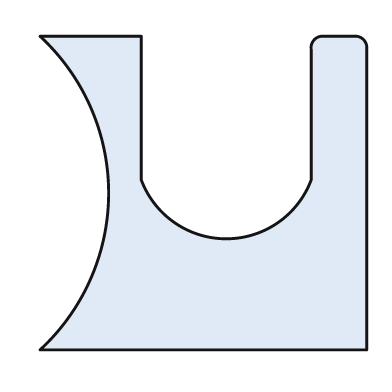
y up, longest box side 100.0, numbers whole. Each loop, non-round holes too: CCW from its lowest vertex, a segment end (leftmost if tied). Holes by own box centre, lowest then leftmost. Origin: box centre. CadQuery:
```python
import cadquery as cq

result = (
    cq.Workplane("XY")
    .moveTo(-50.0, -48.0)
    .lineTo(50.0, -48.0)
    .lineTo(50.0, 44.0)
    .threePointArc((49.0, 47.0), (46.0, 48.0))
    .lineTo(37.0, 48.0)
    .threePointArc((34.0, 47.0), (33.0, 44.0))
    .lineTo(33.0, 4.0)
    .threePointArc((7.0, -14.0), (-19.0, 4.0))
    .lineTo(-19.0, 48.0)
    .lineTo(-50.0, 48.0)
    .threePointArc((-29.0, 0.0), (-50.0, -48.0))
    .close()
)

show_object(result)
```